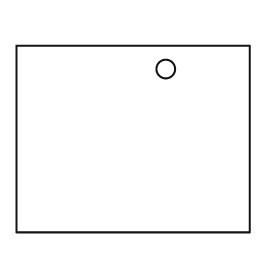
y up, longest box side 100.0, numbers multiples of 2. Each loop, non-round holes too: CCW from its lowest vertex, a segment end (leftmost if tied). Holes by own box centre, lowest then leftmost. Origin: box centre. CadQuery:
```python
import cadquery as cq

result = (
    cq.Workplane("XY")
    .moveTo(-50.0, -40.0)
    .lineTo(50.0, -40.0)
    .lineTo(50.0, 40.0)
    .lineTo(-50.0, 40.0)
    .close()
    .moveTo(14.0, 30.0)
    .circle(4.0)
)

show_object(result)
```